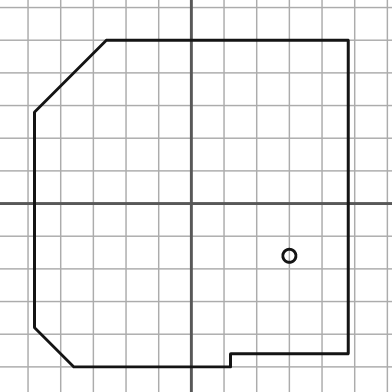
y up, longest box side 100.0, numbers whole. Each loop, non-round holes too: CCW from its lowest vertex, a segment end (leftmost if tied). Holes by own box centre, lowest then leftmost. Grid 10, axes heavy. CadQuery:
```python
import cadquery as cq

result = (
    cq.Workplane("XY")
    .moveTo(-36.0, -50.0)
    .lineTo(12.0, -50.0)
    .lineTo(12.0, -46.0)
    .lineTo(48.0, -46.0)
    .lineTo(48.0, 50.0)
    .lineTo(-26.0, 50.0)
    .lineTo(-48.0, 28.0)
    .lineTo(-48.0, -38.0)
    .close()
    .moveTo(30.0, -16.0)
    .circle(2.0)
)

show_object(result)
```